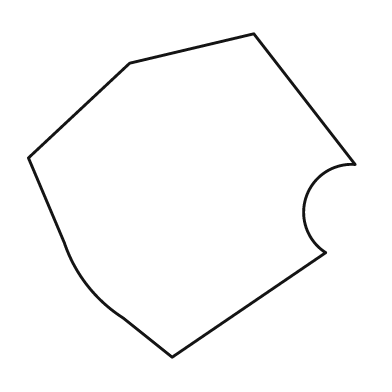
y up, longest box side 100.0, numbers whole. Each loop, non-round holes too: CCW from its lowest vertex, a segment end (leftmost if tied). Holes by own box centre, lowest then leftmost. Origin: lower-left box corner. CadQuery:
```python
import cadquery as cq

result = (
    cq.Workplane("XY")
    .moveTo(44.0, 0.0)
    .lineTo(91.0, 32.0)
    .threePointArc((85.0, 49.0), (100.0, 59.0))
    .lineTo(69.0, 99.0)
    .lineTo(31.0, 90.0)
    .lineTo(0.0, 61.0)
    .lineTo(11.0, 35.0)
    .threePointArc((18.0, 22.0), (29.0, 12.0))
    .close()
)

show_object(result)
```